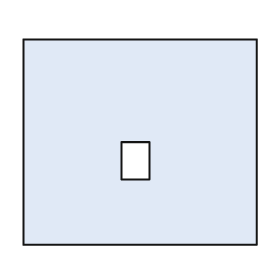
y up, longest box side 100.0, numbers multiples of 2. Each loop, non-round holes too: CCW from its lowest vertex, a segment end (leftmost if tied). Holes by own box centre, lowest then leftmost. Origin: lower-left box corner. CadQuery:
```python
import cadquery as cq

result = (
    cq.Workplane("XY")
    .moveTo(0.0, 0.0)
    .lineTo(100.0, 0.0)
    .lineTo(100.0, 88.0)
    .lineTo(0.0, 88.0)
    .close()
    .moveTo(42.0, 28.0)
    .lineTo(54.0, 28.0)
    .lineTo(54.0, 44.0)
    .lineTo(42.0, 44.0)
    .close()
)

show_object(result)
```